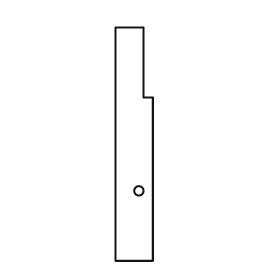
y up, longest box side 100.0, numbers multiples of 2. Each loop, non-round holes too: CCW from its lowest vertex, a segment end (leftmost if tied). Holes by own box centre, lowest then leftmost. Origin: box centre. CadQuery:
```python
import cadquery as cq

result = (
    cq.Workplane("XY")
    .moveTo(-8.0, -50.0)
    .lineTo(8.0, -50.0)
    .lineTo(8.0, 20.0)
    .lineTo(4.0, 20.0)
    .lineTo(4.0, 50.0)
    .lineTo(-8.0, 50.0)
    .close()
    .moveTo(2.0, -20.0)
    .circle(2.0)
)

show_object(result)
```